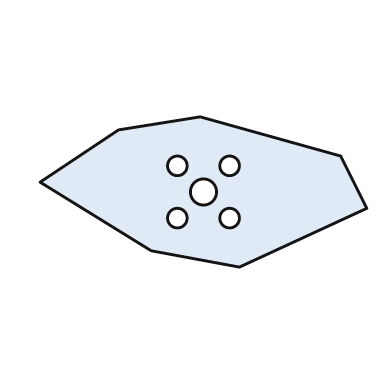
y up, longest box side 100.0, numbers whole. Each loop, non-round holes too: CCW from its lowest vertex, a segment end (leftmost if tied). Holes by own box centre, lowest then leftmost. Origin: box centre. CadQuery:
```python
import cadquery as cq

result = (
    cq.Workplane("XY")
    .moveTo(11.0, -23.0)
    .lineTo(50.0, -5.0)
    .lineTo(42.0, 11.0)
    .lineTo(-1.0, 23.0)
    .lineTo(-26.0, 19.0)
    .lineTo(-50.0, 3.0)
    .lineTo(-16.0, -18.0)
    .close()
    .moveTo(-8.0, -8.0)
    .circle(3.0)
    .moveTo(8.0, -8.0)
    .circle(3.0)
    .moveTo(0.0, 0.0)
    .circle(4.0)
    .moveTo(-8.0, 8.0)
    .circle(3.0)
    .moveTo(8.0, 8.0)
    .circle(3.0)
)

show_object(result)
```